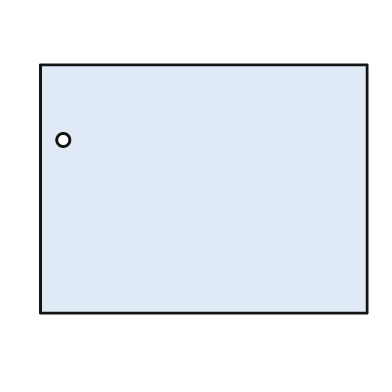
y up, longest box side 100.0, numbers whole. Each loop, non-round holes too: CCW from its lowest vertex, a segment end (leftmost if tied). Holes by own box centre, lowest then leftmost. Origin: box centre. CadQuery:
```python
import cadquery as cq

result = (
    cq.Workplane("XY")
    .moveTo(-50.0, -38.0)
    .lineTo(50.0, -38.0)
    .lineTo(50.0, 38.0)
    .lineTo(-50.0, 38.0)
    .close()
    .moveTo(-43.0, 15.0)
    .circle(2.0)
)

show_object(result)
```